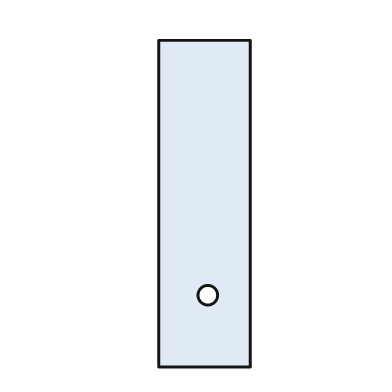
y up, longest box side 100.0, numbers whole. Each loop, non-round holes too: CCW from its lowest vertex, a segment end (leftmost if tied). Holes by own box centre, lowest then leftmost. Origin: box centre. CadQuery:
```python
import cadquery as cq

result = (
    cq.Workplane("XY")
    .moveTo(-14.0, -50.0)
    .lineTo(14.0, -50.0)
    .lineTo(14.0, 50.0)
    .lineTo(-14.0, 50.0)
    .close()
    .moveTo(1.0, -28.0)
    .circle(3.0)
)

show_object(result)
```